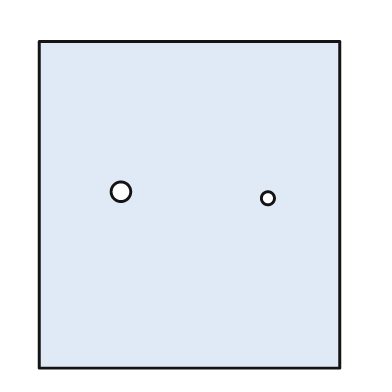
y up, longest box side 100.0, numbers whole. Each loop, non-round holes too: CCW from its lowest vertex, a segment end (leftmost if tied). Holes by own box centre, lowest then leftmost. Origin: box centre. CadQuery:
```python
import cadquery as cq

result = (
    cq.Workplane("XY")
    .moveTo(-46.0, -50.0)
    .lineTo(46.0, -50.0)
    .lineTo(46.0, 50.0)
    .lineTo(-46.0, 50.0)
    .close()
    .moveTo(24.0, 2.0)
    .circle(2.0)
    .moveTo(-21.0, 4.0)
    .circle(3.0)
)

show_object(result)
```